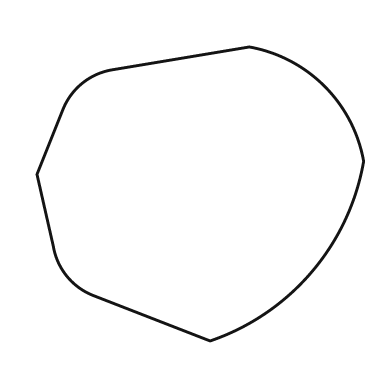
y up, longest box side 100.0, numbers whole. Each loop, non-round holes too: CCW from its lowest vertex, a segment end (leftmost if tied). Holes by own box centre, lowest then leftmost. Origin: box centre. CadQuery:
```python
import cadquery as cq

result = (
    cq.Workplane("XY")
    .moveTo(3.0, -45.0)
    .threePointArc((34.0, -24.0), (50.0, 10.0))
    .threePointArc((38.0, 33.0), (15.0, 45.0))
    .lineTo(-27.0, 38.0)
    .threePointArc((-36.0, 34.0), (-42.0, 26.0))
    .lineTo(-50.0, 6.0)
    .lineTo(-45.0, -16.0)
    .threePointArc((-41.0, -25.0), (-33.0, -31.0))
    .close()
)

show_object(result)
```